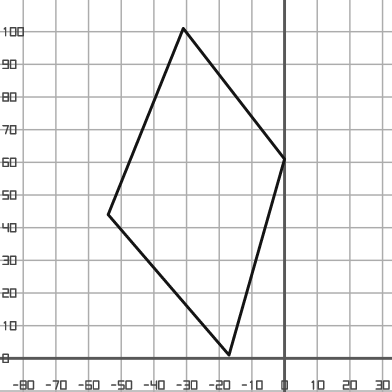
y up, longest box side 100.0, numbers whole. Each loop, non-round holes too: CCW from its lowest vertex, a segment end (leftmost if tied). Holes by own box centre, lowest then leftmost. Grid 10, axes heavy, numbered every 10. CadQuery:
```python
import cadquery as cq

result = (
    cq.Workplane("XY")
    .moveTo(-17.0, 1.0)
    .lineTo(0.0, 61.0)
    .lineTo(-31.0, 101.0)
    .lineTo(-54.0, 44.0)
    .close()
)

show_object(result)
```